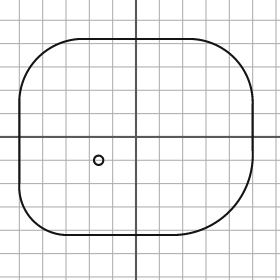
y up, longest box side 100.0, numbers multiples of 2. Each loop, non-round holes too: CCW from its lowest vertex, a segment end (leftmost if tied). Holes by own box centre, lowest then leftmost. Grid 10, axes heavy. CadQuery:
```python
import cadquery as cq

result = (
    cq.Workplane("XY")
    .moveTo(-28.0, -42.0)
    .lineTo(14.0, -42.0)
    .threePointArc((40.0, -32.0), (50.0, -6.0))
    .lineTo(50.0, 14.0)
    .threePointArc((42.0, 34.0), (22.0, 42.0))
    .lineTo(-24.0, 42.0)
    .threePointArc((-42.0, 34.0), (-50.0, 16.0))
    .lineTo(-50.0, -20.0)
    .threePointArc((-44.0, -36.0), (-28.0, -42.0))
    .close()
    .moveTo(-16.0, -10.0)
    .circle(2.0)
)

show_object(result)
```